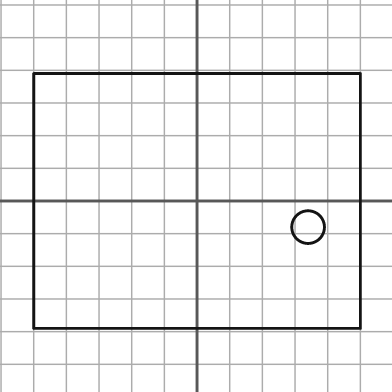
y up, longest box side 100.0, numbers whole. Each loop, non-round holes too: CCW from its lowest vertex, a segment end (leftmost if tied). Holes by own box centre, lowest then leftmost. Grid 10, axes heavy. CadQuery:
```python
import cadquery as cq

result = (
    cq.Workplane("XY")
    .moveTo(-50.0, -39.0)
    .lineTo(50.0, -39.0)
    .lineTo(50.0, 39.0)
    .lineTo(-50.0, 39.0)
    .close()
    .moveTo(34.0, -8.0)
    .circle(5.0)
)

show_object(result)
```